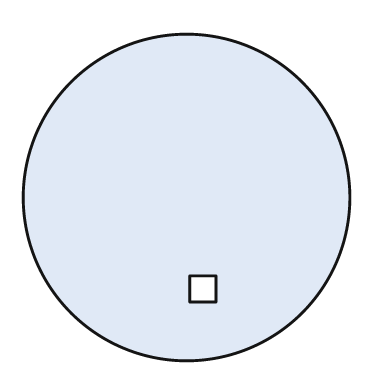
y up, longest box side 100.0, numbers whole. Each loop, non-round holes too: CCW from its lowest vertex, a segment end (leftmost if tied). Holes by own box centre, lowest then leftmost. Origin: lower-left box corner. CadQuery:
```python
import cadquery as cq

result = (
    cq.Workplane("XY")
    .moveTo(50.0, 50.0)
    .circle(50.0)
    .moveTo(51.0, 18.0)
    .lineTo(59.0, 18.0)
    .lineTo(59.0, 26.0)
    .lineTo(51.0, 26.0)
    .close()
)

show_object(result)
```